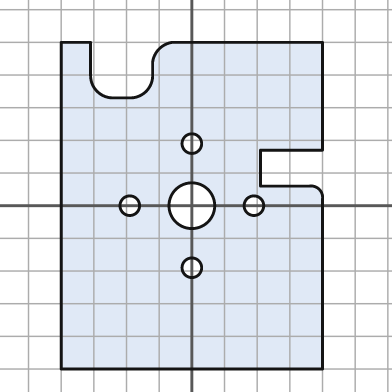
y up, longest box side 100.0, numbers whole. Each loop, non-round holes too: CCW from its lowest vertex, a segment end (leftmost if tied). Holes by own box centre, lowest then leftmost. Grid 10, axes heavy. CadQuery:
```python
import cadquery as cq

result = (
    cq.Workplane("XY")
    .moveTo(-40.0, -50.0)
    .lineTo(40.0, -50.0)
    .lineTo(40.0, 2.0)
    .threePointArc((39.0, 5.0), (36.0, 6.0))
    .lineTo(21.0, 6.0)
    .lineTo(21.0, 17.0)
    .lineTo(40.0, 17.0)
    .lineTo(40.0, 50.0)
    .lineTo(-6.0, 50.0)
    .threePointArc((-10.0, 48.0), (-12.0, 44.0))
    .lineTo(-12.0, 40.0)
    .threePointArc((-14.0, 35.0), (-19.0, 33.0))
    .lineTo(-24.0, 33.0)
    .threePointArc((-29.0, 35.0), (-31.0, 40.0))
    .lineTo(-31.0, 50.0)
    .lineTo(-40.0, 50.0)
    .close()
    .moveTo(0.0, -19.0)
    .circle(3.0)
    .moveTo(-19.0, 0.0)
    .circle(3.0)
    .moveTo(0.0, 0.0)
    .circle(7.0)
    .moveTo(19.0, 0.0)
    .circle(3.0)
    .moveTo(0.0, 19.0)
    .circle(3.0)
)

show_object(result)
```